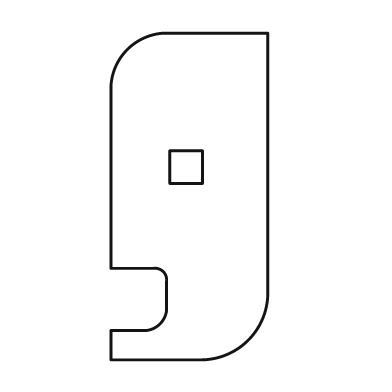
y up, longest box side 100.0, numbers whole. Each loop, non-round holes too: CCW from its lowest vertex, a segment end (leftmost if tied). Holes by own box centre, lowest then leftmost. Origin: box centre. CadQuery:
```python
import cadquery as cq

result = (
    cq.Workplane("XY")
    .moveTo(-24.0, -50.0)
    .lineTo(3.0, -50.0)
    .threePointArc((18.0, -44.0), (24.0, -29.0))
    .lineTo(24.0, 50.0)
    .lineTo(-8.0, 50.0)
    .threePointArc((-19.0, 45.0), (-24.0, 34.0))
    .lineTo(-24.0, -22.0)
    .lineTo(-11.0, -22.0)
    .threePointArc((-8.0, -23.0), (-7.0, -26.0))
    .lineTo(-7.0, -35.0)
    .threePointArc((-9.0, -39.0), (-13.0, -41.0))
    .lineTo(-24.0, -41.0)
    .close()
    .moveTo(-6.0, 4.0)
    .lineTo(4.0, 4.0)
    .lineTo(4.0, 14.0)
    .lineTo(-6.0, 14.0)
    .close()
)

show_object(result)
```